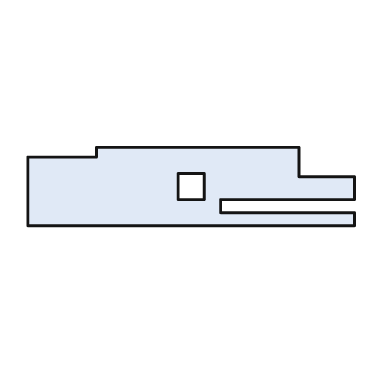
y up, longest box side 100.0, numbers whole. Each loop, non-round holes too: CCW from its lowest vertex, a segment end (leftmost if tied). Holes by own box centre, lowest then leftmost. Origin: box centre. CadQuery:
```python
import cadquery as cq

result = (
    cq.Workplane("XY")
    .moveTo(-50.0, -12.0)
    .lineTo(50.0, -12.0)
    .lineTo(50.0, -8.0)
    .lineTo(9.0, -8.0)
    .lineTo(9.0, -4.0)
    .lineTo(50.0, -4.0)
    .lineTo(50.0, 3.0)
    .lineTo(33.0, 3.0)
    .lineTo(33.0, 12.0)
    .lineTo(-29.0, 12.0)
    .lineTo(-29.0, 9.0)
    .lineTo(-50.0, 9.0)
    .close()
    .moveTo(-4.0, -4.0)
    .lineTo(4.0, -4.0)
    .lineTo(4.0, 4.0)
    .lineTo(-4.0, 4.0)
    .close()
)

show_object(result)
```